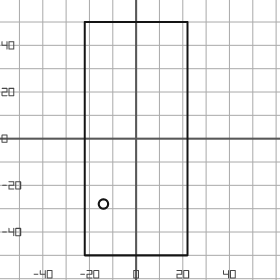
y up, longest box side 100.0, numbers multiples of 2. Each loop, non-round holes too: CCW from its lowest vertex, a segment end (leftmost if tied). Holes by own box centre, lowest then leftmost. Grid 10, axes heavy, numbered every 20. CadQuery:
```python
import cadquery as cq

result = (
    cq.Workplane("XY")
    .moveTo(-22.0, -50.0)
    .lineTo(22.0, -50.0)
    .lineTo(22.0, 50.0)
    .lineTo(-22.0, 50.0)
    .close()
    .moveTo(-14.0, -28.0)
    .circle(2.0)
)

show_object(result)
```